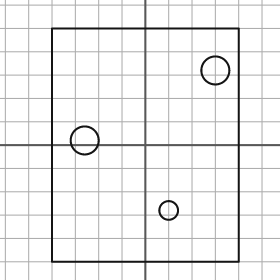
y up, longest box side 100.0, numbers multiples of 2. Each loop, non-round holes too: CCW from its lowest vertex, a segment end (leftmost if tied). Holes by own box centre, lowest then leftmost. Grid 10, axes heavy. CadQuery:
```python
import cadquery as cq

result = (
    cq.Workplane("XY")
    .moveTo(-40.0, -50.0)
    .lineTo(40.0, -50.0)
    .lineTo(40.0, 50.0)
    .lineTo(-40.0, 50.0)
    .close()
    .moveTo(10.0, -28.0)
    .circle(4.0)
    .moveTo(-26.0, 2.0)
    .circle(6.0)
    .moveTo(30.0, 32.0)
    .circle(6.0)
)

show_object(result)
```